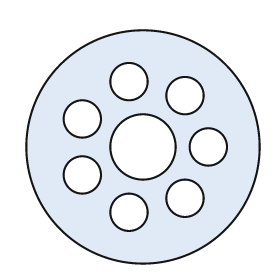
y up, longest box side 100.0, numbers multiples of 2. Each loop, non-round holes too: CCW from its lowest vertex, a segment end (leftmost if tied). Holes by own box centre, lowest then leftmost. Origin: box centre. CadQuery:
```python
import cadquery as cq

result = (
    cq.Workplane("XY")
    .moveTo(0.0, 0.0)
    .circle(50.0)
    .moveTo(-6.0, -28.0)
    .circle(8.0)
    .moveTo(18.0, -22.0)
    .circle(8.0)
    .moveTo(-26.0, -12.0)
    .circle(8.0)
    .moveTo(0.0, 0.0)
    .circle(14.0)
    .moveTo(28.0, 0.0)
    .circle(8.0)
    .moveTo(-26.0, 12.0)
    .circle(8.0)
    .moveTo(18.0, 22.0)
    .circle(8.0)
    .moveTo(-6.0, 28.0)
    .circle(8.0)
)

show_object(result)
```